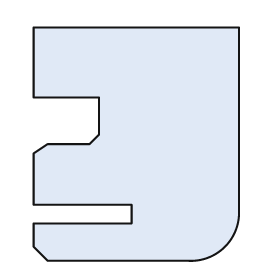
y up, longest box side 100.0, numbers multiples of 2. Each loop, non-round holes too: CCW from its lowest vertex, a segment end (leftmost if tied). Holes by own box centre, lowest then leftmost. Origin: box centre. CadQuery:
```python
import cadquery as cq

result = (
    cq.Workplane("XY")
    .moveTo(-38.0, -50.0)
    .lineTo(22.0, -50.0)
    .threePointArc((38.0, -44.0), (44.0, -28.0))
    .lineTo(44.0, 50.0)
    .lineTo(-44.0, 50.0)
    .lineTo(-44.0, 20.0)
    .lineTo(-16.0, 20.0)
    .lineTo(-16.0, 4.0)
    .lineTo(-20.0, 0.0)
    .lineTo(-38.0, 0.0)
    .lineTo(-44.0, -4.0)
    .lineTo(-44.0, -26.0)
    .lineTo(-2.0, -26.0)
    .lineTo(-2.0, -34.0)
    .lineTo(-44.0, -34.0)
    .lineTo(-44.0, -44.0)
    .close()
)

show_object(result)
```